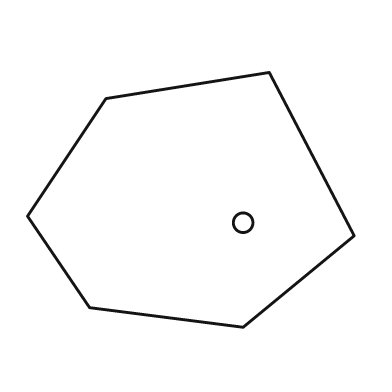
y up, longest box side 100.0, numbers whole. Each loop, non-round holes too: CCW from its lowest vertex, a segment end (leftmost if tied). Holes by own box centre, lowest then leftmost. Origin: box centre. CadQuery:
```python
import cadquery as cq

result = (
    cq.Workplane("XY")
    .moveTo(16.0, -39.0)
    .lineTo(50.0, -11.0)
    .lineTo(24.0, 39.0)
    .lineTo(-26.0, 31.0)
    .lineTo(-50.0, -5.0)
    .lineTo(-31.0, -33.0)
    .close()
    .moveTo(16.0, -7.0)
    .circle(3.0)
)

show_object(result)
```